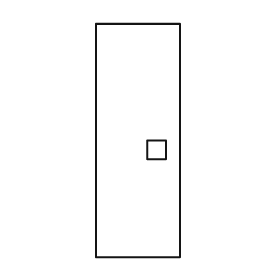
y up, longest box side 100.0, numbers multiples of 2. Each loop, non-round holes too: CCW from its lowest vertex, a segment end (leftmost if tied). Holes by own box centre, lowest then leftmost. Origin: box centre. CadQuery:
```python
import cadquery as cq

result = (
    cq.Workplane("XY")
    .moveTo(-18.0, -50.0)
    .lineTo(18.0, -50.0)
    .lineTo(18.0, 50.0)
    .lineTo(-18.0, 50.0)
    .close()
    .moveTo(4.0, -8.0)
    .lineTo(12.0, -8.0)
    .lineTo(12.0, 0.0)
    .lineTo(4.0, 0.0)
    .close()
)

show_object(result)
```